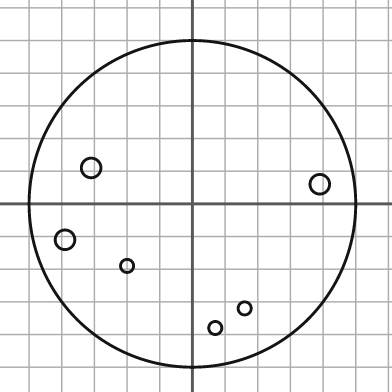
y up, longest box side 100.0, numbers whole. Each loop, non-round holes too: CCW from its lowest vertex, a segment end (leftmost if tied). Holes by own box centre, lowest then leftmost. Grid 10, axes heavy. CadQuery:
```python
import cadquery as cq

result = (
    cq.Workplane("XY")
    .moveTo(0.0, 0.0)
    .circle(50.0)
    .moveTo(7.0, -38.0)
    .circle(2.0)
    .moveTo(16.0, -32.0)
    .circle(2.0)
    .moveTo(-20.0, -19.0)
    .circle(2.0)
    .moveTo(-39.0, -11.0)
    .circle(3.0)
    .moveTo(39.0, 6.0)
    .circle(3.0)
    .moveTo(-31.0, 11.0)
    .circle(3.0)
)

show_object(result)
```